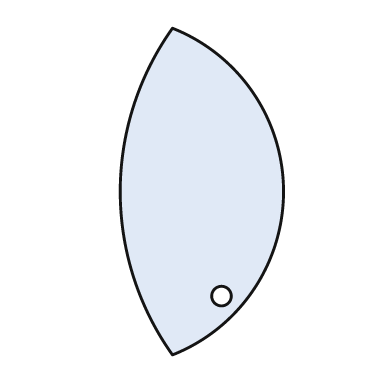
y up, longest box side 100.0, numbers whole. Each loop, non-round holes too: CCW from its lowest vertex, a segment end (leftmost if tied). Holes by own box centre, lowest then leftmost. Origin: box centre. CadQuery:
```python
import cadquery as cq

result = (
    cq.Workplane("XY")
    .moveTo(-9.0, -50.0)
    .threePointArc((25.0, 0.0), (-9.0, 50.0))
    .threePointArc((-25.0, 0.0), (-9.0, -50.0))
    .close()
    .moveTo(6.0, -32.0)
    .circle(3.0)
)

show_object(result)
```